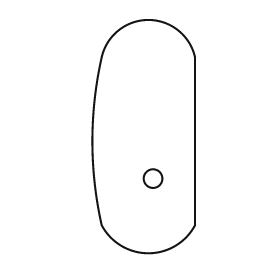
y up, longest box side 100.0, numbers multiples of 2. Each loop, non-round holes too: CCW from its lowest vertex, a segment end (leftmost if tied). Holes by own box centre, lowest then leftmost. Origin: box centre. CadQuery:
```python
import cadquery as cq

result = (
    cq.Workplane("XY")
    .moveTo(-18.0, -38.0)
    .threePointArc((2.0, -50.0), (22.0, -38.0))
    .lineTo(22.0, 34.0)
    .threePointArc((2.0, 50.0), (-18.0, 34.0))
    .threePointArc((-22.0, -2.0), (-18.0, -38.0))
    .close()
    .moveTo(4.0, -18.0)
    .circle(4.0)
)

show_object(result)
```